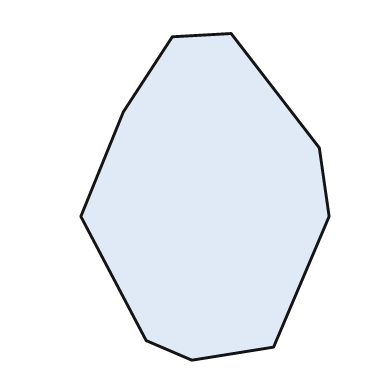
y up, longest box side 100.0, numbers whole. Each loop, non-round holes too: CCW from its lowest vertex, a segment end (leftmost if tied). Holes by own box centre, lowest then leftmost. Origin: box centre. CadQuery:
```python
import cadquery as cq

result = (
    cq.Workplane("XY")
    .moveTo(-4.0, -50.0)
    .lineTo(21.0, -46.0)
    .lineTo(38.0, -6.0)
    .lineTo(35.0, 15.0)
    .lineTo(8.0, 50.0)
    .lineTo(-10.0, 49.0)
    .lineTo(-25.0, 26.0)
    .lineTo(-38.0, -6.0)
    .lineTo(-18.0, -44.0)
    .close()
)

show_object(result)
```